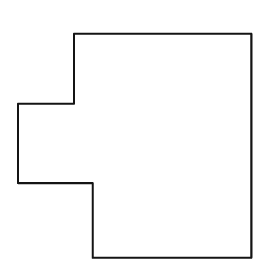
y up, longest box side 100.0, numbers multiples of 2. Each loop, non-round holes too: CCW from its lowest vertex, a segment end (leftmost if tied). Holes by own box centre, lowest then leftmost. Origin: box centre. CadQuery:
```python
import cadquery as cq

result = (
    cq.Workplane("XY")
    .moveTo(-18.0, -48.0)
    .lineTo(50.0, -48.0)
    .lineTo(50.0, 48.0)
    .lineTo(-26.0, 48.0)
    .lineTo(-26.0, 18.0)
    .lineTo(-50.0, 18.0)
    .lineTo(-50.0, -16.0)
    .lineTo(-18.0, -16.0)
    .close()
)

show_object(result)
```